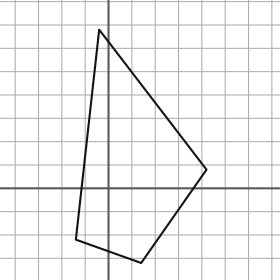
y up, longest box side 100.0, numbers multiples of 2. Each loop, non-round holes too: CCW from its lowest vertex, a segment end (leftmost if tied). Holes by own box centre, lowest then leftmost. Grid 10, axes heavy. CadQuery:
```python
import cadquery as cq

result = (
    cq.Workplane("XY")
    .moveTo(14.0, -32.0)
    .lineTo(42.0, 8.0)
    .lineTo(-4.0, 68.0)
    .lineTo(-14.0, -22.0)
    .close()
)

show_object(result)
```